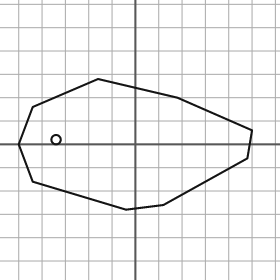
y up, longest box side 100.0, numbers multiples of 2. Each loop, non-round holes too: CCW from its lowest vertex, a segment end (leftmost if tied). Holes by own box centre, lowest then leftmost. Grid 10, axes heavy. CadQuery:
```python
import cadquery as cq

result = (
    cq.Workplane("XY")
    .moveTo(-4.0, -28.0)
    .lineTo(12.0, -26.0)
    .lineTo(48.0, -6.0)
    .lineTo(50.0, 6.0)
    .lineTo(18.0, 20.0)
    .lineTo(-16.0, 28.0)
    .lineTo(-44.0, 16.0)
    .lineTo(-50.0, 0.0)
    .lineTo(-44.0, -16.0)
    .close()
    .moveTo(-34.0, 2.0)
    .circle(2.0)
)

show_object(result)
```